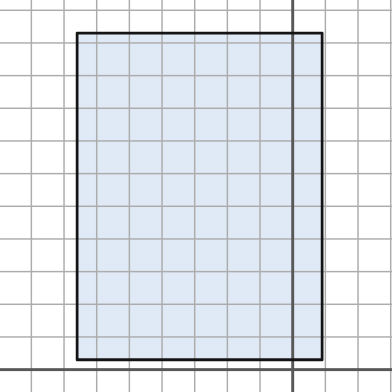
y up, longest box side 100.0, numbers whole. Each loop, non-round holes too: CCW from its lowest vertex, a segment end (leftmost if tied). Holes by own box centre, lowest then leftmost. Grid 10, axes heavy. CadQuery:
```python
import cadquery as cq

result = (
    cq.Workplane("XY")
    .moveTo(-66.0, 3.0)
    .lineTo(9.0, 3.0)
    .lineTo(9.0, 103.0)
    .lineTo(-66.0, 103.0)
    .close()
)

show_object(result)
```